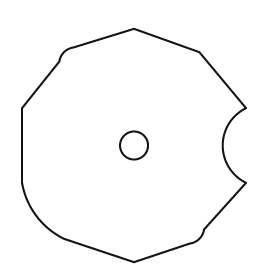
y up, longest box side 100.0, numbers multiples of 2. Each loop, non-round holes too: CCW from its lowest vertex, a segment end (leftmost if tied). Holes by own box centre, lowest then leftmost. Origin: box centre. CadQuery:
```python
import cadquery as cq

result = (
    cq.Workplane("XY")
    .moveTo(0.0, -50.0)
    .lineTo(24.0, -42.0)
    .threePointArc((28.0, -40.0), (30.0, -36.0))
    .lineTo(48.0, -16.0)
    .threePointArc((38.0, 0.0), (48.0, 16.0))
    .lineTo(28.0, 40.0)
    .lineTo(0.0, 50.0)
    .lineTo(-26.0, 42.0)
    .threePointArc((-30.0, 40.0), (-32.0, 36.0))
    .lineTo(-48.0, 16.0)
    .lineTo(-48.0, -16.0)
    .threePointArc((-42.0, -30.0), (-30.0, -40.0))
    .close()
    .moveTo(0.0, 0.0)
    .circle(6.0)
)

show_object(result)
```